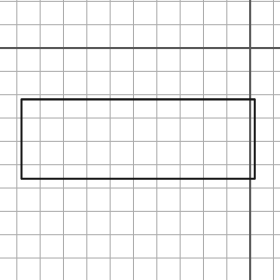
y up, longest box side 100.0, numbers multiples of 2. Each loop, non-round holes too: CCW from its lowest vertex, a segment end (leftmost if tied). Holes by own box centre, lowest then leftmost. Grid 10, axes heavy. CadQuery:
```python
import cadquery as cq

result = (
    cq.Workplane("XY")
    .moveTo(-98.0, -56.0)
    .lineTo(2.0, -56.0)
    .lineTo(2.0, -22.0)
    .lineTo(-98.0, -22.0)
    .close()
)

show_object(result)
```